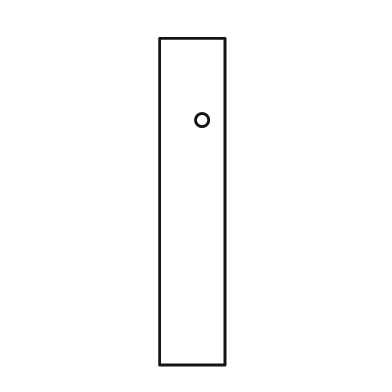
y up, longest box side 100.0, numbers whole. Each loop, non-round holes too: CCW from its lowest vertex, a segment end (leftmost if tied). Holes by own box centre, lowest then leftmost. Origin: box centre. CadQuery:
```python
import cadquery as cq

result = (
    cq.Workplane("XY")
    .moveTo(-10.0, -50.0)
    .lineTo(10.0, -50.0)
    .lineTo(10.0, 50.0)
    .lineTo(-10.0, 50.0)
    .close()
    .moveTo(3.0, 25.0)
    .circle(2.0)
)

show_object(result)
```